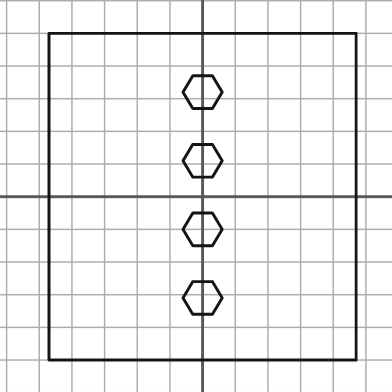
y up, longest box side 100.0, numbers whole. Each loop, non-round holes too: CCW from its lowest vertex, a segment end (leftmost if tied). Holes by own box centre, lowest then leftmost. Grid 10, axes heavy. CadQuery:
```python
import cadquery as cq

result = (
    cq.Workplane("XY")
    .moveTo(-47.0, -50.0)
    .lineTo(47.0, -50.0)
    .lineTo(47.0, 50.0)
    .lineTo(-47.0, 50.0)
    .close()
    .moveTo(-3.0, -36.0)
    .lineTo(3.0, -36.0)
    .lineTo(6.0, -31.0)
    .lineTo(3.0, -26.0)
    .lineTo(-3.0, -26.0)
    .lineTo(-6.0, -31.0)
    .close()
    .moveTo(-3.0, -15.0)
    .lineTo(3.0, -15.0)
    .lineTo(6.0, -10.0)
    .lineTo(3.0, -5.0)
    .lineTo(-3.0, -5.0)
    .lineTo(-6.0, -10.0)
    .close()
    .moveTo(-3.0, 6.0)
    .lineTo(3.0, 6.0)
    .lineTo(6.0, 11.0)
    .lineTo(3.0, 16.0)
    .lineTo(-3.0, 16.0)
    .lineTo(-6.0, 11.0)
    .close()
    .moveTo(-3.0, 27.0)
    .lineTo(3.0, 27.0)
    .lineTo(6.0, 32.0)
    .lineTo(3.0, 37.0)
    .lineTo(-3.0, 37.0)
    .lineTo(-6.0, 32.0)
    .close()
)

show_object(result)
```